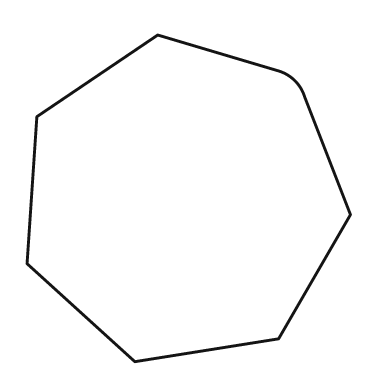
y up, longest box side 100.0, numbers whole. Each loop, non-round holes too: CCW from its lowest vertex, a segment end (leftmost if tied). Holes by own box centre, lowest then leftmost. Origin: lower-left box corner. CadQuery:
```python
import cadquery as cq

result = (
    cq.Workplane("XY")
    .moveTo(33.0, 0.0)
    .lineTo(77.0, 7.0)
    .lineTo(99.0, 45.0)
    .lineTo(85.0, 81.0)
    .threePointArc((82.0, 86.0), (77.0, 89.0))
    .lineTo(40.0, 100.0)
    .lineTo(3.0, 75.0)
    .lineTo(0.0, 30.0)
    .close()
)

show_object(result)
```